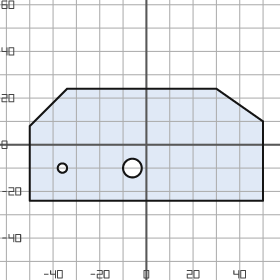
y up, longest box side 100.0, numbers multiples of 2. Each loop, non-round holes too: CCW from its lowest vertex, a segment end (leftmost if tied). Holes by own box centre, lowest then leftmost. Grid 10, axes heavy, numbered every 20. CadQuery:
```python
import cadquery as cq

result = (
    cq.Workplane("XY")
    .moveTo(-50.0, -24.0)
    .lineTo(50.0, -24.0)
    .lineTo(50.0, 10.0)
    .lineTo(30.0, 24.0)
    .lineTo(-34.0, 24.0)
    .lineTo(-50.0, 8.0)
    .close()
    .moveTo(-36.0, -10.0)
    .circle(2.0)
    .moveTo(-6.0, -10.0)
    .circle(4.0)
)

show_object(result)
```